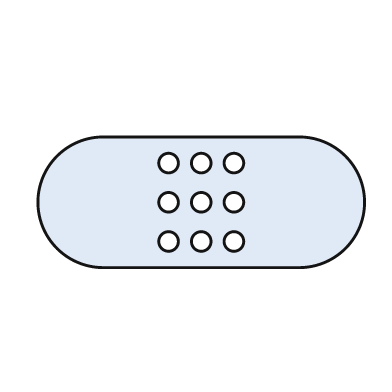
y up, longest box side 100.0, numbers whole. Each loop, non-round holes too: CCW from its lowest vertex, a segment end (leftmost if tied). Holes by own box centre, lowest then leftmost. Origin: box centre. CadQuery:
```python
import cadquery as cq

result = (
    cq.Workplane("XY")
    .moveTo(-30.0, -20.0)
    .lineTo(30.0, -20.0)
    .threePointArc((50.0, 0.0), (30.0, 20.0))
    .lineTo(-30.0, 20.0)
    .threePointArc((-50.0, 0.0), (-30.0, -20.0))
    .close()
    .moveTo(-10.0, -12.0)
    .circle(3.0)
    .moveTo(0.0, -12.0)
    .circle(3.0)
    .moveTo(10.0, -12.0)
    .circle(3.0)
    .moveTo(-10.0, 0.0)
    .circle(3.0)
    .moveTo(0.0, 0.0)
    .circle(3.0)
    .moveTo(10.0, 0.0)
    .circle(3.0)
    .moveTo(-10.0, 12.0)
    .circle(3.0)
    .moveTo(0.0, 12.0)
    .circle(3.0)
    .moveTo(10.0, 12.0)
    .circle(3.0)
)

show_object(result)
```